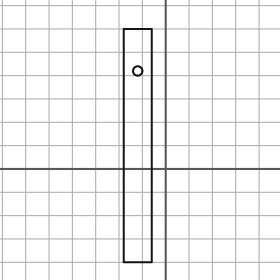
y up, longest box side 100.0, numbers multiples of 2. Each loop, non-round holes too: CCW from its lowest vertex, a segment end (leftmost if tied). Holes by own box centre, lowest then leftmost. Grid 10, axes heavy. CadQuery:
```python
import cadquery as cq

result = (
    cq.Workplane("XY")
    .moveTo(-18.0, -40.0)
    .lineTo(-6.0, -40.0)
    .lineTo(-6.0, 60.0)
    .lineTo(-18.0, 60.0)
    .close()
    .moveTo(-12.0, 42.0)
    .circle(2.0)
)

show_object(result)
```